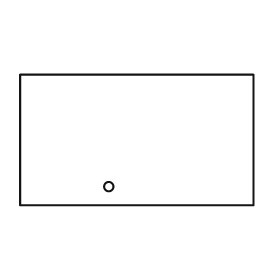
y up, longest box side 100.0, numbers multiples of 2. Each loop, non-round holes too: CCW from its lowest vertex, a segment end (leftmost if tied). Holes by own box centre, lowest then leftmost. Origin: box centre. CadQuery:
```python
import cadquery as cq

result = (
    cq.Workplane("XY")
    .moveTo(-50.0, -28.0)
    .lineTo(50.0, -28.0)
    .lineTo(50.0, 28.0)
    .lineTo(-50.0, 28.0)
    .close()
    .moveTo(-12.0, -20.0)
    .circle(2.0)
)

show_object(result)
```